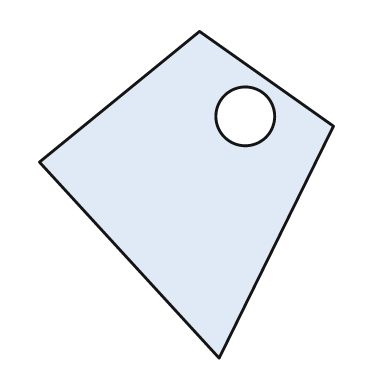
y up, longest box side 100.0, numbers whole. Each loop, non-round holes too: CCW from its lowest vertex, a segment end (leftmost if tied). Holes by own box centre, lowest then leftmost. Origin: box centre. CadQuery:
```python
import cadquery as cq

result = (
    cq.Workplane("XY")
    .moveTo(10.0, -50.0)
    .lineTo(45.0, 21.0)
    .lineTo(4.0, 50.0)
    .lineTo(-45.0, 10.0)
    .close()
    .moveTo(18.0, 24.0)
    .circle(9.0)
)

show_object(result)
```